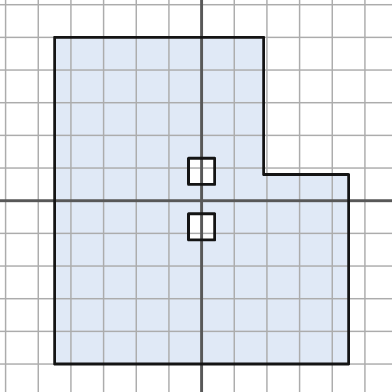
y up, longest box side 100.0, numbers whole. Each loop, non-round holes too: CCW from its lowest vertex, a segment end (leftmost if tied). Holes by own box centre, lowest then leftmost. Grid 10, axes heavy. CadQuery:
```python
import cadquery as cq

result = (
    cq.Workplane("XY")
    .moveTo(-45.0, -50.0)
    .lineTo(45.0, -50.0)
    .lineTo(45.0, 8.0)
    .lineTo(19.0, 8.0)
    .lineTo(19.0, 50.0)
    .lineTo(-45.0, 50.0)
    .close()
    .moveTo(-4.0, -12.0)
    .lineTo(4.0, -12.0)
    .lineTo(4.0, -4.0)
    .lineTo(-4.0, -4.0)
    .close()
    .moveTo(-4.0, 5.0)
    .lineTo(4.0, 5.0)
    .lineTo(4.0, 13.0)
    .lineTo(-4.0, 13.0)
    .close()
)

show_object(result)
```